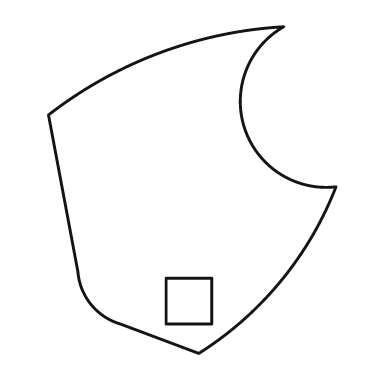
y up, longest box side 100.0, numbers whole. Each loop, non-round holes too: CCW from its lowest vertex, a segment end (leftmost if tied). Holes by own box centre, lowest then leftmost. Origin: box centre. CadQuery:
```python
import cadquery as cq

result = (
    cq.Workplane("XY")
    .moveTo(2.0, -50.0)
    .threePointArc((27.0, -28.0), (44.0, 1.0))
    .threePointArc((16.0, 19.0), (28.0, 50.0))
    .threePointArc((-10.0, 42.0), (-44.0, 23.0))
    .lineTo(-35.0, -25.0)
    .threePointArc((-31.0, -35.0), (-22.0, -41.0))
    .close()
    .moveTo(-8.0, -41.0)
    .lineTo(6.0, -41.0)
    .lineTo(6.0, -27.0)
    .lineTo(-8.0, -27.0)
    .close()
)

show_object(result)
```